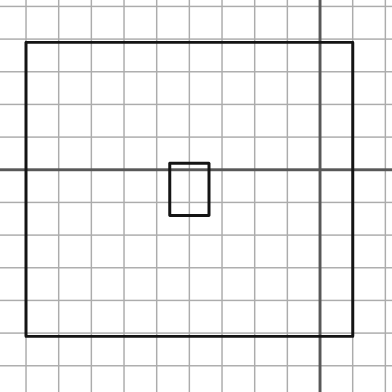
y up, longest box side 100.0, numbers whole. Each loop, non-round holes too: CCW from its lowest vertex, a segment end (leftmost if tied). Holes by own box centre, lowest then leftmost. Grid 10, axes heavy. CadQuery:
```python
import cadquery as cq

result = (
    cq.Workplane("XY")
    .moveTo(-90.0, -51.0)
    .lineTo(10.0, -51.0)
    .lineTo(10.0, 39.0)
    .lineTo(-90.0, 39.0)
    .close()
    .moveTo(-46.0, -14.0)
    .lineTo(-34.0, -14.0)
    .lineTo(-34.0, 2.0)
    .lineTo(-46.0, 2.0)
    .close()
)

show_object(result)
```